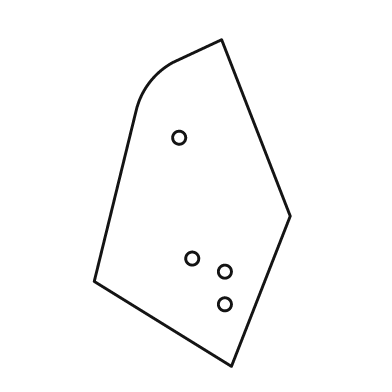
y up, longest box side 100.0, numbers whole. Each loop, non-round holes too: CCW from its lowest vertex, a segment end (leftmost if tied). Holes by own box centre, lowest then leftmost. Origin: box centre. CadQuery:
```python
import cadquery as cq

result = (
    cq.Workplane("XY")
    .moveTo(12.0, -50.0)
    .lineTo(30.0, -4.0)
    .lineTo(9.0, 50.0)
    .lineTo(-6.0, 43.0)
    .threePointArc((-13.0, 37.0), (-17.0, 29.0))
    .lineTo(-30.0, -24.0)
    .close()
    .moveTo(10.0, -31.0)
    .circle(2.0)
    .moveTo(10.0, -21.0)
    .circle(2.0)
    .moveTo(0.0, -17.0)
    .circle(2.0)
    .moveTo(-4.0, 20.0)
    .circle(2.0)
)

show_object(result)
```